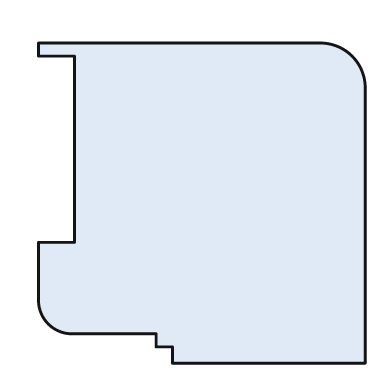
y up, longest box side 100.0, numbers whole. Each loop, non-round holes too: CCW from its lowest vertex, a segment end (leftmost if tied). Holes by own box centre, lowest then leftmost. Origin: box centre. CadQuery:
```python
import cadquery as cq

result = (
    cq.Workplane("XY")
    .moveTo(-9.0, -49.0)
    .lineTo(50.0, -49.0)
    .lineTo(50.0, 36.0)
    .threePointArc((46.0, 45.0), (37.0, 49.0))
    .lineTo(-50.0, 49.0)
    .lineTo(-50.0, 45.0)
    .lineTo(-39.0, 45.0)
    .lineTo(-39.0, -12.0)
    .lineTo(-50.0, -12.0)
    .lineTo(-50.0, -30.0)
    .threePointArc((-47.0, -37.0), (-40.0, -40.0))
    .lineTo(-14.0, -40.0)
    .lineTo(-14.0, -44.0)
    .lineTo(-9.0, -44.0)
    .close()
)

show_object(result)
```